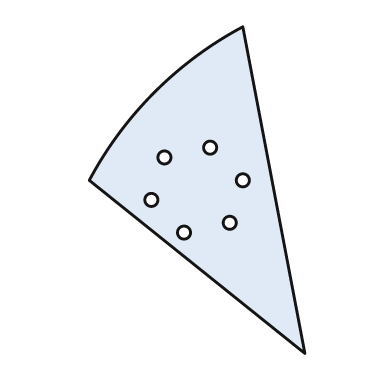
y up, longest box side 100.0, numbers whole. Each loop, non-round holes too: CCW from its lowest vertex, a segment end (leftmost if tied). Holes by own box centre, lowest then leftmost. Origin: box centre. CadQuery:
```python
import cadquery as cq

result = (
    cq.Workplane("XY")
    .moveTo(33.0, -50.0)
    .lineTo(14.0, 50.0)
    .threePointArc((-13.0, 30.0), (-33.0, 3.0))
    .close()
    .moveTo(-4.0, -13.0)
    .circle(2.0)
    .moveTo(10.0, -10.0)
    .circle(2.0)
    .moveTo(-14.0, -3.0)
    .circle(2.0)
    .moveTo(14.0, 3.0)
    .circle(2.0)
    .moveTo(-10.0, 10.0)
    .circle(2.0)
    .moveTo(4.0, 13.0)
    .circle(2.0)
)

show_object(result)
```